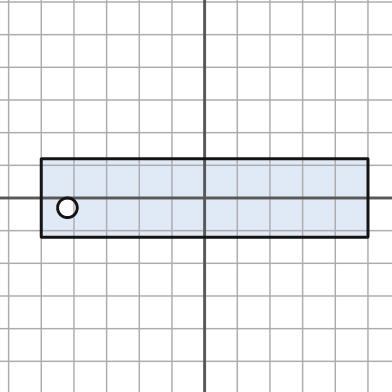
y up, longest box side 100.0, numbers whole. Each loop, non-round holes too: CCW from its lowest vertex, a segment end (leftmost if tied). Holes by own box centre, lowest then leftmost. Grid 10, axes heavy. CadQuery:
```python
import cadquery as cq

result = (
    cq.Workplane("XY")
    .moveTo(-50.0, -12.0)
    .lineTo(50.0, -12.0)
    .lineTo(50.0, 12.0)
    .lineTo(-50.0, 12.0)
    .close()
    .moveTo(-42.0, -3.0)
    .circle(3.0)
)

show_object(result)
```